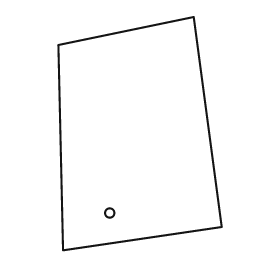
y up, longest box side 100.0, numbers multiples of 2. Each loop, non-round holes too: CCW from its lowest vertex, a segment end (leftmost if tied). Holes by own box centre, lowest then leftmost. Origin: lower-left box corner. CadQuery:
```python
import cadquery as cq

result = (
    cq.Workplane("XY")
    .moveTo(2.0, 0.0)
    .lineTo(70.0, 10.0)
    .lineTo(58.0, 100.0)
    .lineTo(0.0, 88.0)
    .close()
    .moveTo(22.0, 16.0)
    .circle(2.0)
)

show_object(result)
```